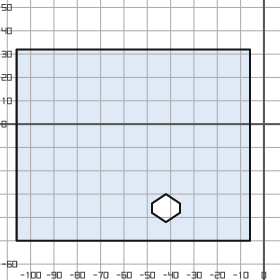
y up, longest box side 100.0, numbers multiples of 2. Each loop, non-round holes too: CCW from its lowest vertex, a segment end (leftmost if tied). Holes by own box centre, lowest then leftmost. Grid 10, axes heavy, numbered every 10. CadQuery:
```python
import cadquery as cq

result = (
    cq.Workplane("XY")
    .moveTo(-106.0, -50.0)
    .lineTo(-6.0, -50.0)
    .lineTo(-6.0, 32.0)
    .lineTo(-106.0, 32.0)
    .close()
    .moveTo(-42.0, -42.0)
    .lineTo(-36.0, -38.0)
    .lineTo(-36.0, -34.0)
    .lineTo(-42.0, -30.0)
    .lineTo(-48.0, -34.0)
    .lineTo(-48.0, -38.0)
    .close()
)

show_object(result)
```